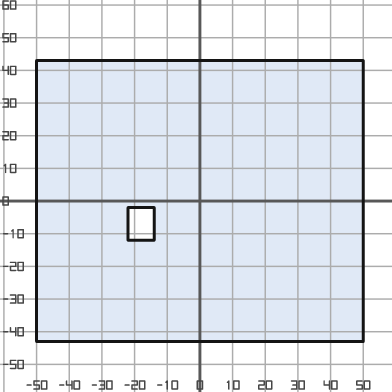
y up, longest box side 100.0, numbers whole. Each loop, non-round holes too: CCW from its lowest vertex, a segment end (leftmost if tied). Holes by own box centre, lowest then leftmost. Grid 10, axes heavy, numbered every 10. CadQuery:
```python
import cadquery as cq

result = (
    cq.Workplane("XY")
    .moveTo(-50.0, -43.0)
    .lineTo(50.0, -43.0)
    .lineTo(50.0, 43.0)
    .lineTo(-50.0, 43.0)
    .close()
    .moveTo(-22.0, -12.0)
    .lineTo(-14.0, -12.0)
    .lineTo(-14.0, -2.0)
    .lineTo(-22.0, -2.0)
    .close()
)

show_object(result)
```